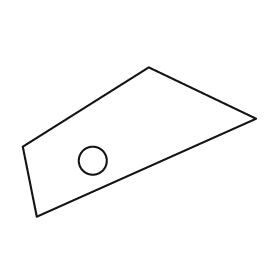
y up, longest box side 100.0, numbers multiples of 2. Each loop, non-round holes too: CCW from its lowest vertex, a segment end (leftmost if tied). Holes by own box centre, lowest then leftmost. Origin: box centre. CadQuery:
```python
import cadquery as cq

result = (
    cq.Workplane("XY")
    .moveTo(-44.0, -32.0)
    .lineTo(50.0, 10.0)
    .lineTo(4.0, 32.0)
    .lineTo(-50.0, -2.0)
    .close()
    .moveTo(-20.0, -8.0)
    .circle(6.0)
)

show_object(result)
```